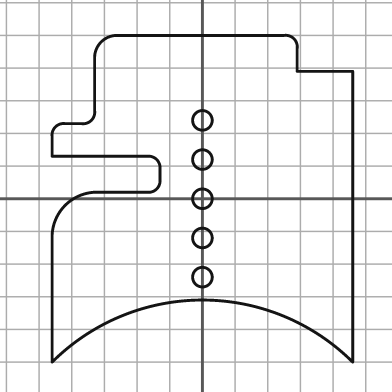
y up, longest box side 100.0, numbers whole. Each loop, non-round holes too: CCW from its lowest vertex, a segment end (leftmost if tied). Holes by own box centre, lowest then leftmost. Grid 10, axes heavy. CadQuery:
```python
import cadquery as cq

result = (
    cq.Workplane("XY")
    .moveTo(-46.0, -50.0)
    .threePointArc((0.0, -31.0), (46.0, -50.0))
    .lineTo(46.0, 39.0)
    .lineTo(29.0, 39.0)
    .lineTo(29.0, 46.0)
    .threePointArc((28.0, 49.0), (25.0, 50.0))
    .lineTo(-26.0, 50.0)
    .threePointArc((-31.0, 48.0), (-33.0, 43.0))
    .lineTo(-33.0, 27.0)
    .threePointArc((-34.0, 24.0), (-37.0, 23.0))
    .lineTo(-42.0, 23.0)
    .threePointArc((-45.0, 22.0), (-46.0, 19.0))
    .lineTo(-46.0, 13.0)
    .lineTo(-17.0, 13.0)
    .threePointArc((-14.0, 12.0), (-13.0, 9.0))
    .lineTo(-13.0, 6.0)
    .threePointArc((-14.0, 3.0), (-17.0, 2.0))
    .lineTo(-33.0, 2.0)
    .threePointArc((-42.0, -2.0), (-46.0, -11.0))
    .close()
    .moveTo(0.0, -24.0)
    .circle(3.0)
    .moveTo(0.0, -12.0)
    .circle(3.0)
    .moveTo(0.0, 0.0)
    .circle(3.0)
    .moveTo(0.0, 12.0)
    .circle(3.0)
    .moveTo(0.0, 24.0)
    .circle(3.0)
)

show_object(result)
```